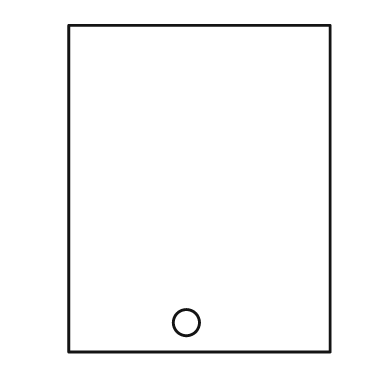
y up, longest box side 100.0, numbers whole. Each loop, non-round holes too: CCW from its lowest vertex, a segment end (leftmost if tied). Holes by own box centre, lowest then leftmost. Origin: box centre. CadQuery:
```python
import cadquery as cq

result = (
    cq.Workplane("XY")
    .moveTo(-40.0, -50.0)
    .lineTo(40.0, -50.0)
    .lineTo(40.0, 50.0)
    .lineTo(-40.0, 50.0)
    .close()
    .moveTo(-4.0, -41.0)
    .circle(4.0)
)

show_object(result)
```